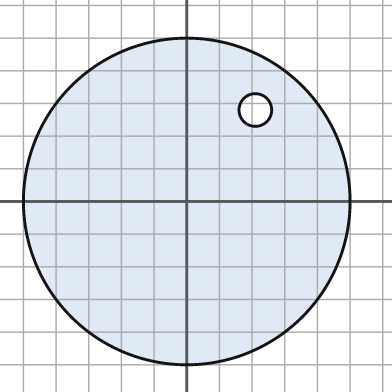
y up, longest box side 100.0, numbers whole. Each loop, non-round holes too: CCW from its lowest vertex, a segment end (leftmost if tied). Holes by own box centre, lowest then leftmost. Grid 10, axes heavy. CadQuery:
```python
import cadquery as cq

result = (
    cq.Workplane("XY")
    .moveTo(0.0, 0.0)
    .circle(50.0)
    .moveTo(21.0, 28.0)
    .circle(5.0)
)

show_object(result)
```